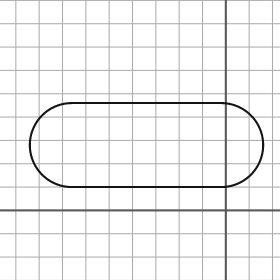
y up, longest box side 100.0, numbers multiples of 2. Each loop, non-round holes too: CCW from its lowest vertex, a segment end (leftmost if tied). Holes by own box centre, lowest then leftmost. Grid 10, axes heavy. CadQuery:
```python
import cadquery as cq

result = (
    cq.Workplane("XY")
    .moveTo(-66.0, 10.0)
    .lineTo(-2.0, 10.0)
    .threePointArc((16.0, 28.0), (-2.0, 46.0))
    .lineTo(-66.0, 46.0)
    .threePointArc((-84.0, 28.0), (-66.0, 10.0))
    .close()
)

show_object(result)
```